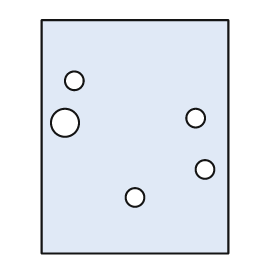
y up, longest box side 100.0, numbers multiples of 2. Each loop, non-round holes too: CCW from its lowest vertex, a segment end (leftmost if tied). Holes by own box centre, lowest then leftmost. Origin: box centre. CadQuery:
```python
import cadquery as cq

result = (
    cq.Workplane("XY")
    .moveTo(-40.0, -50.0)
    .lineTo(40.0, -50.0)
    .lineTo(40.0, 50.0)
    .lineTo(-40.0, 50.0)
    .close()
    .moveTo(0.0, -26.0)
    .circle(4.0)
    .moveTo(30.0, -14.0)
    .circle(4.0)
    .moveTo(-30.0, 6.0)
    .circle(6.0)
    .moveTo(26.0, 8.0)
    .circle(4.0)
    .moveTo(-26.0, 24.0)
    .circle(4.0)
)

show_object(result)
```